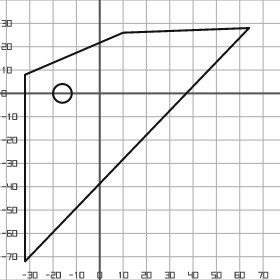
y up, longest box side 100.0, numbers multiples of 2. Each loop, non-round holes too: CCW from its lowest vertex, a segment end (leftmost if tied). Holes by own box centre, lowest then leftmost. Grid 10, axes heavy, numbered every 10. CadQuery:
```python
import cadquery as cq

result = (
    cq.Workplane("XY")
    .moveTo(-32.0, -72.0)
    .lineTo(64.0, 28.0)
    .lineTo(10.0, 26.0)
    .lineTo(-32.0, 8.0)
    .close()
    .moveTo(-16.0, 0.0)
    .circle(4.0)
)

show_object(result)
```